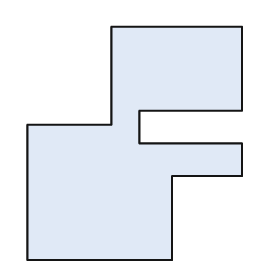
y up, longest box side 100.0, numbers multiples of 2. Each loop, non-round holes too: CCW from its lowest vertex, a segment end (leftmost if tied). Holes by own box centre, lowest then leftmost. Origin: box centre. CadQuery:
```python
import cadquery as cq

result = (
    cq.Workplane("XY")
    .moveTo(-46.0, -50.0)
    .lineTo(16.0, -50.0)
    .lineTo(16.0, -14.0)
    .lineTo(46.0, -14.0)
    .lineTo(46.0, 0.0)
    .lineTo(2.0, 0.0)
    .lineTo(2.0, 14.0)
    .lineTo(46.0, 14.0)
    .lineTo(46.0, 50.0)
    .lineTo(-10.0, 50.0)
    .lineTo(-10.0, 8.0)
    .lineTo(-46.0, 8.0)
    .close()
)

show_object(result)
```